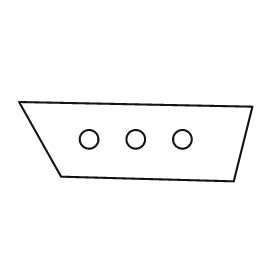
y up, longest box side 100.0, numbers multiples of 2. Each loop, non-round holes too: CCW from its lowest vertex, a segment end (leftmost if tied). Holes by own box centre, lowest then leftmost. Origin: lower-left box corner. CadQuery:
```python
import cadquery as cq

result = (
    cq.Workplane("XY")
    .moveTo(92.0, 0.0)
    .lineTo(100.0, 32.0)
    .lineTo(0.0, 34.0)
    .lineTo(18.0, 2.0)
    .close()
    .moveTo(30.0, 18.0)
    .circle(4.0)
    .moveTo(50.0, 18.0)
    .circle(4.0)
    .moveTo(70.0, 18.0)
    .circle(4.0)
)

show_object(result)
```